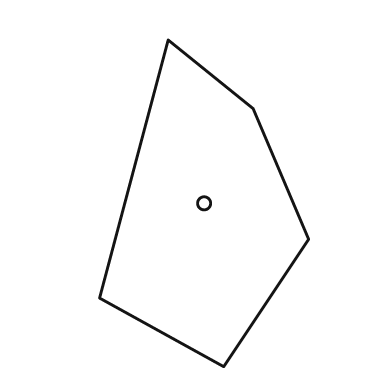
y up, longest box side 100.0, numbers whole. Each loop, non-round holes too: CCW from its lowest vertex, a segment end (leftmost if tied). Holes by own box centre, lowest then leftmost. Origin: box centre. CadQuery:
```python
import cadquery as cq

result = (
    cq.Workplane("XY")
    .moveTo(6.0, -50.0)
    .lineTo(32.0, -11.0)
    .lineTo(15.0, 29.0)
    .lineTo(-11.0, 50.0)
    .lineTo(-32.0, -29.0)
    .close()
    .moveTo(0.0, 0.0)
    .circle(2.0)
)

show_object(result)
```